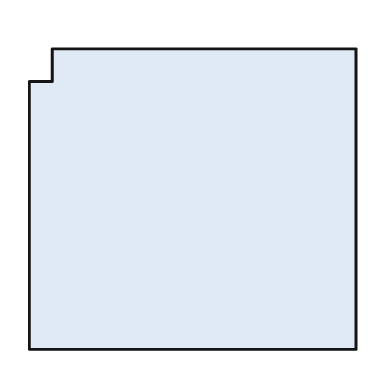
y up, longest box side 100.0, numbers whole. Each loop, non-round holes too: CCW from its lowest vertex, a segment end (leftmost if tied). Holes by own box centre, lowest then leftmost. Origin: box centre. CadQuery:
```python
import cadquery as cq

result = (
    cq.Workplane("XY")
    .moveTo(-50.0, -46.0)
    .lineTo(50.0, -46.0)
    .lineTo(50.0, 46.0)
    .lineTo(-43.0, 46.0)
    .lineTo(-43.0, 36.0)
    .lineTo(-50.0, 36.0)
    .close()
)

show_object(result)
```